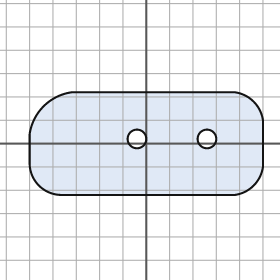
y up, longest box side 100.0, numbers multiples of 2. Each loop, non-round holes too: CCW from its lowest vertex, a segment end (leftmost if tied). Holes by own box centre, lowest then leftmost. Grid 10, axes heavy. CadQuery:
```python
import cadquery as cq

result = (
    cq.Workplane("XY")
    .moveTo(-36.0, -22.0)
    .lineTo(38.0, -22.0)
    .threePointArc((46.0, -18.0), (50.0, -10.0))
    .lineTo(50.0, 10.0)
    .threePointArc((46.0, 18.0), (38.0, 22.0))
    .lineTo(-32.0, 22.0)
    .threePointArc((-44.0, 16.0), (-50.0, 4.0))
    .lineTo(-50.0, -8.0)
    .threePointArc((-46.0, -18.0), (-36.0, -22.0))
    .close()
    .moveTo(-4.0, 2.0)
    .circle(4.0)
    .moveTo(26.0, 2.0)
    .circle(4.0)
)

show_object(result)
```